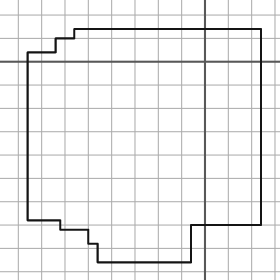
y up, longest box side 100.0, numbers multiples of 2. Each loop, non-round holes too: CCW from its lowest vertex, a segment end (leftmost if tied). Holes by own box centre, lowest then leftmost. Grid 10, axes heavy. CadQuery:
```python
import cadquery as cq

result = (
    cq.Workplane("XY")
    .moveTo(-46.0, -86.0)
    .lineTo(-6.0, -86.0)
    .lineTo(-6.0, -70.0)
    .lineTo(24.0, -70.0)
    .lineTo(24.0, 14.0)
    .lineTo(-56.0, 14.0)
    .lineTo(-56.0, 10.0)
    .lineTo(-64.0, 10.0)
    .lineTo(-64.0, 4.0)
    .lineTo(-76.0, 4.0)
    .lineTo(-76.0, -68.0)
    .lineTo(-62.0, -68.0)
    .lineTo(-62.0, -72.0)
    .lineTo(-50.0, -72.0)
    .lineTo(-50.0, -78.0)
    .lineTo(-46.0, -78.0)
    .close()
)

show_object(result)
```